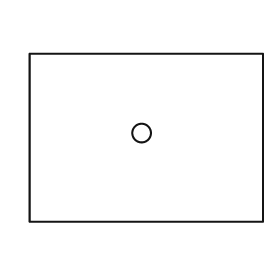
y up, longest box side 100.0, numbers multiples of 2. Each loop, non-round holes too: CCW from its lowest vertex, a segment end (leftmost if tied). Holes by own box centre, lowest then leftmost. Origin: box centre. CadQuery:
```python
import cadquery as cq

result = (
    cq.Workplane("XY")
    .moveTo(-50.0, -36.0)
    .lineTo(50.0, -36.0)
    .lineTo(50.0, 36.0)
    .lineTo(-50.0, 36.0)
    .close()
    .moveTo(-2.0, 2.0)
    .circle(4.0)
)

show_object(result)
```